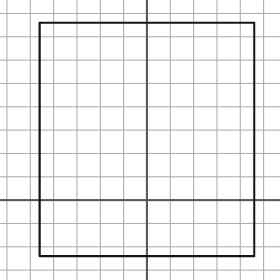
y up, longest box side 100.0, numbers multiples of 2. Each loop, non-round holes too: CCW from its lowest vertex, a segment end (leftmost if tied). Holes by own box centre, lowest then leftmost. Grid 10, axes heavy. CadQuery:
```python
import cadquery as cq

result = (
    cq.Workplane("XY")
    .moveTo(-46.0, -24.0)
    .lineTo(46.0, -24.0)
    .lineTo(46.0, 76.0)
    .lineTo(-46.0, 76.0)
    .close()
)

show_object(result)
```